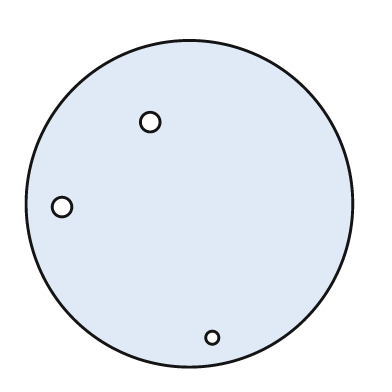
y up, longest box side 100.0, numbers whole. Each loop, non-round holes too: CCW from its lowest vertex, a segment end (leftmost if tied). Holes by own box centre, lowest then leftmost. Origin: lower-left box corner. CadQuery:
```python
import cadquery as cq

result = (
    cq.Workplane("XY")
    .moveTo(50.0, 50.0)
    .circle(50.0)
    .moveTo(57.0, 9.0)
    .circle(2.0)
    .moveTo(11.0, 49.0)
    .circle(3.0)
    .moveTo(38.0, 75.0)
    .circle(3.0)
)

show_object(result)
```